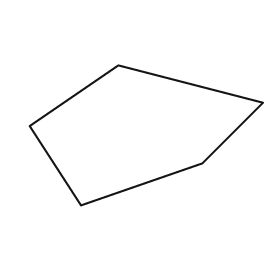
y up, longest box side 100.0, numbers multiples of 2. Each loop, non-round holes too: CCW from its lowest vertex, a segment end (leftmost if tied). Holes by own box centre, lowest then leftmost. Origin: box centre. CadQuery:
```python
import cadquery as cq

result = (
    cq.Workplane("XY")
    .moveTo(-28.0, -30.0)
    .lineTo(24.0, -12.0)
    .lineTo(50.0, 14.0)
    .lineTo(-12.0, 30.0)
    .lineTo(-50.0, 4.0)
    .close()
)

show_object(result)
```